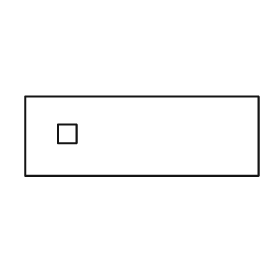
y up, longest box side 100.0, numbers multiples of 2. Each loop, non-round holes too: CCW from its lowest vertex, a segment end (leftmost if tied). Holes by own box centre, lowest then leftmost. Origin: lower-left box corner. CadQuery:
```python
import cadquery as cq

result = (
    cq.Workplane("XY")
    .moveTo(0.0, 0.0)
    .lineTo(100.0, 0.0)
    .lineTo(100.0, 34.0)
    .lineTo(0.0, 34.0)
    .close()
    .moveTo(14.0, 14.0)
    .lineTo(22.0, 14.0)
    .lineTo(22.0, 22.0)
    .lineTo(14.0, 22.0)
    .close()
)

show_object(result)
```